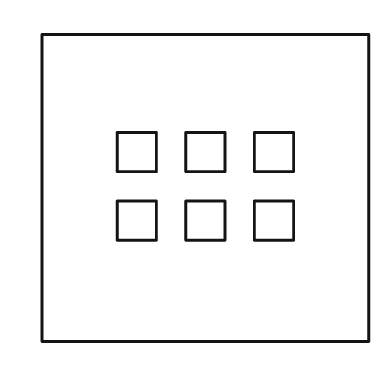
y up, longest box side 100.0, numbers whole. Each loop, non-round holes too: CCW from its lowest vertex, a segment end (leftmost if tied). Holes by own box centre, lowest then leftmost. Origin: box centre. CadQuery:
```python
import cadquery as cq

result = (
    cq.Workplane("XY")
    .moveTo(-50.0, -47.0)
    .lineTo(50.0, -47.0)
    .lineTo(50.0, 47.0)
    .lineTo(-50.0, 47.0)
    .close()
    .moveTo(-27.0, -16.0)
    .lineTo(-15.0, -16.0)
    .lineTo(-15.0, -4.0)
    .lineTo(-27.0, -4.0)
    .close()
    .moveTo(-6.0, -16.0)
    .lineTo(6.0, -16.0)
    .lineTo(6.0, -4.0)
    .lineTo(-6.0, -4.0)
    .close()
    .moveTo(15.0, -16.0)
    .lineTo(27.0, -16.0)
    .lineTo(27.0, -4.0)
    .lineTo(15.0, -4.0)
    .close()
    .moveTo(-27.0, 5.0)
    .lineTo(-15.0, 5.0)
    .lineTo(-15.0, 17.0)
    .lineTo(-27.0, 17.0)
    .close()
    .moveTo(-6.0, 5.0)
    .lineTo(6.0, 5.0)
    .lineTo(6.0, 17.0)
    .lineTo(-6.0, 17.0)
    .close()
    .moveTo(15.0, 5.0)
    .lineTo(27.0, 5.0)
    .lineTo(27.0, 17.0)
    .lineTo(15.0, 17.0)
    .close()
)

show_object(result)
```